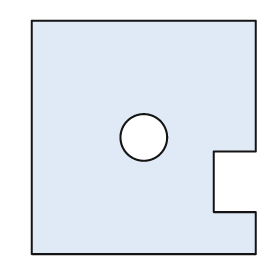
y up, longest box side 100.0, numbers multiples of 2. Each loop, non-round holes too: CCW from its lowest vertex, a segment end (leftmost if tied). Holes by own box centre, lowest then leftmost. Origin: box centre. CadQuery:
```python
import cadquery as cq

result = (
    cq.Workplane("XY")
    .moveTo(-48.0, -50.0)
    .lineTo(48.0, -50.0)
    .lineTo(48.0, -32.0)
    .lineTo(30.0, -32.0)
    .lineTo(30.0, -6.0)
    .lineTo(48.0, -6.0)
    .lineTo(48.0, 50.0)
    .lineTo(-48.0, 50.0)
    .close()
    .moveTo(0.0, 0.0)
    .circle(10.0)
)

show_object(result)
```